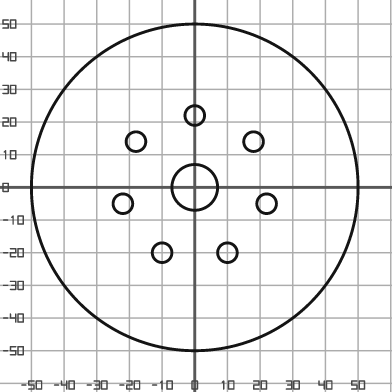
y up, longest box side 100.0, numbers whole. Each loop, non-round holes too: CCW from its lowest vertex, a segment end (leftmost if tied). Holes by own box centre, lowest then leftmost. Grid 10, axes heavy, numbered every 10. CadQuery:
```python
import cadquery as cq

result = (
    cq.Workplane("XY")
    .moveTo(0.0, 0.0)
    .circle(50.0)
    .moveTo(-10.0, -20.0)
    .circle(3.0)
    .moveTo(10.0, -20.0)
    .circle(3.0)
    .moveTo(-22.0, -5.0)
    .circle(3.0)
    .moveTo(22.0, -5.0)
    .circle(3.0)
    .moveTo(0.0, 0.0)
    .circle(7.0)
    .moveTo(-18.0, 14.0)
    .circle(3.0)
    .moveTo(18.0, 14.0)
    .circle(3.0)
    .moveTo(0.0, 22.0)
    .circle(3.0)
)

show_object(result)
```